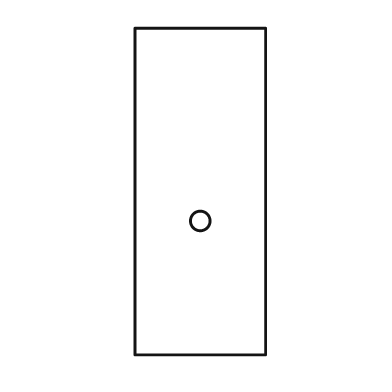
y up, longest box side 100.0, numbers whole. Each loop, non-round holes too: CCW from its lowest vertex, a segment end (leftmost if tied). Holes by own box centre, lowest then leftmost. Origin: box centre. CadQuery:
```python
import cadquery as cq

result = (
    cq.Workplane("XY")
    .moveTo(-20.0, -50.0)
    .lineTo(20.0, -50.0)
    .lineTo(20.0, 50.0)
    .lineTo(-20.0, 50.0)
    .close()
    .moveTo(0.0, -9.0)
    .circle(3.0)
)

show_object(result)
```